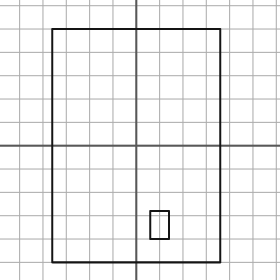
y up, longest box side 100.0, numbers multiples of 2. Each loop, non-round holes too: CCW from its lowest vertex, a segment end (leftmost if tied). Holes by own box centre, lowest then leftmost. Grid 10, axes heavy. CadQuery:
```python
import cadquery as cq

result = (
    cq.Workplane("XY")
    .moveTo(-36.0, -50.0)
    .lineTo(36.0, -50.0)
    .lineTo(36.0, 50.0)
    .lineTo(-36.0, 50.0)
    .close()
    .moveTo(6.0, -40.0)
    .lineTo(14.0, -40.0)
    .lineTo(14.0, -28.0)
    .lineTo(6.0, -28.0)
    .close()
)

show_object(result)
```